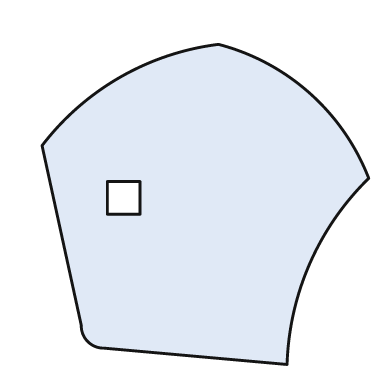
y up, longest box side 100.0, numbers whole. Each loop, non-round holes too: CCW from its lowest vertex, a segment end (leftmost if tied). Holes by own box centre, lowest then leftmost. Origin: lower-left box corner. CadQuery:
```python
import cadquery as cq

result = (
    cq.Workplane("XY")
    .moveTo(75.0, 0.0)
    .threePointArc((82.0, 31.0), (100.0, 57.0))
    .threePointArc((82.0, 83.0), (54.0, 98.0))
    .threePointArc((24.0, 88.0), (0.0, 67.0))
    .lineTo(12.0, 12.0)
    .threePointArc((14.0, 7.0), (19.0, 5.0))
    .close()
    .moveTo(20.0, 46.0)
    .lineTo(30.0, 46.0)
    .lineTo(30.0, 56.0)
    .lineTo(20.0, 56.0)
    .close()
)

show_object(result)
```